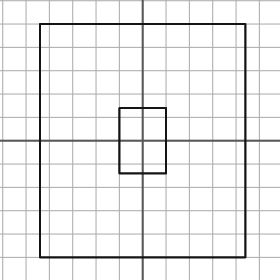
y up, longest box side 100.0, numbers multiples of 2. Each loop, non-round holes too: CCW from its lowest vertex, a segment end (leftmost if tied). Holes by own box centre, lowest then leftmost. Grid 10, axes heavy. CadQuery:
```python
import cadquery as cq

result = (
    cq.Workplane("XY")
    .moveTo(-44.0, -50.0)
    .lineTo(44.0, -50.0)
    .lineTo(44.0, 50.0)
    .lineTo(-44.0, 50.0)
    .close()
    .moveTo(-10.0, -14.0)
    .lineTo(10.0, -14.0)
    .lineTo(10.0, 14.0)
    .lineTo(-10.0, 14.0)
    .close()
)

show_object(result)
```